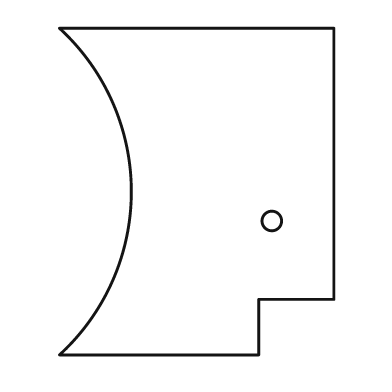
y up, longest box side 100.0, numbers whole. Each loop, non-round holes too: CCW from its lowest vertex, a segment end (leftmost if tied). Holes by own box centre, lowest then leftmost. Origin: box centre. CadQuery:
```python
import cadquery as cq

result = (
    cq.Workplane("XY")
    .moveTo(-42.0, -50.0)
    .lineTo(19.0, -50.0)
    .lineTo(19.0, -33.0)
    .lineTo(42.0, -33.0)
    .lineTo(42.0, 50.0)
    .lineTo(-42.0, 50.0)
    .threePointArc((-20.0, 0.0), (-42.0, -50.0))
    .close()
    .moveTo(23.0, -9.0)
    .circle(3.0)
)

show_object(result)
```